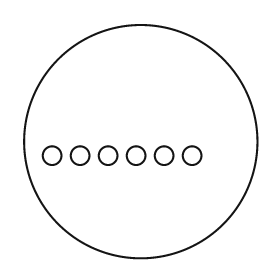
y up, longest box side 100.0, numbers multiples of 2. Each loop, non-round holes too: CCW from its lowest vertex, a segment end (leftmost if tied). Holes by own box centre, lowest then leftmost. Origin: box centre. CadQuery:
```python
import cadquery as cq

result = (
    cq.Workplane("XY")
    .moveTo(0.0, 0.0)
    .circle(50.0)
    .moveTo(-38.0, -6.0)
    .circle(4.0)
    .moveTo(-26.0, -6.0)
    .circle(4.0)
    .moveTo(-14.0, -6.0)
    .circle(4.0)
    .moveTo(-2.0, -6.0)
    .circle(4.0)
    .moveTo(10.0, -6.0)
    .circle(4.0)
    .moveTo(22.0, -6.0)
    .circle(4.0)
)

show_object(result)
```